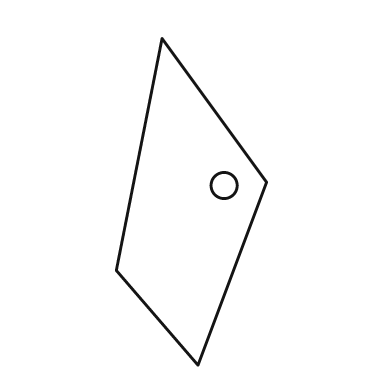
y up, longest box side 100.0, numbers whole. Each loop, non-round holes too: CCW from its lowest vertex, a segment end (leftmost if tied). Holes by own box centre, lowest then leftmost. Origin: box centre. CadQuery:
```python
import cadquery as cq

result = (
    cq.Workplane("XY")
    .moveTo(2.0, -50.0)
    .lineTo(23.0, 6.0)
    .lineTo(-9.0, 50.0)
    .lineTo(-23.0, -21.0)
    .close()
    .moveTo(10.0, 5.0)
    .circle(4.0)
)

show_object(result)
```